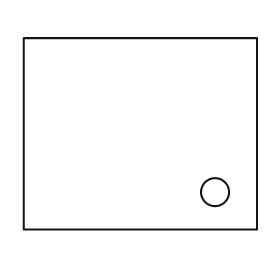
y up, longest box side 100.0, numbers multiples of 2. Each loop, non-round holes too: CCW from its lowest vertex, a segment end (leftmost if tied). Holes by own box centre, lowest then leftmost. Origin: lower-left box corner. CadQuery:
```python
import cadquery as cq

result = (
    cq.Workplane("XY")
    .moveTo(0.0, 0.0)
    .lineTo(100.0, 0.0)
    .lineTo(100.0, 82.0)
    .lineTo(0.0, 82.0)
    .close()
    .moveTo(82.0, 16.0)
    .circle(6.0)
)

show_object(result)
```